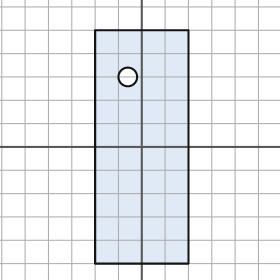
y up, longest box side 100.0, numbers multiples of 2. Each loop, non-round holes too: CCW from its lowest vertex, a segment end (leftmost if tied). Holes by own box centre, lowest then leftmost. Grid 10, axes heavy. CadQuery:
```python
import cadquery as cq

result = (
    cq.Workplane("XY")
    .moveTo(-20.0, -50.0)
    .lineTo(20.0, -50.0)
    .lineTo(20.0, 50.0)
    .lineTo(-20.0, 50.0)
    .close()
    .moveTo(-6.0, 30.0)
    .circle(4.0)
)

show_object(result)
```